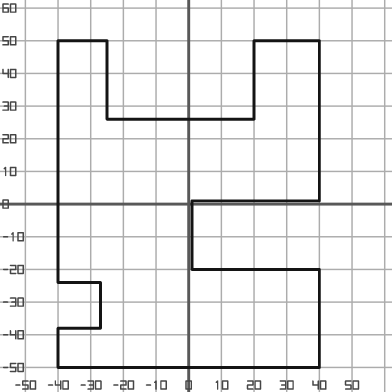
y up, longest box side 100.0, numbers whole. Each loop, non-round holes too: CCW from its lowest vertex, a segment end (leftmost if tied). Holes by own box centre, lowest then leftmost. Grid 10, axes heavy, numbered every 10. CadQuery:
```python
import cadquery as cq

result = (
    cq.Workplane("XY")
    .moveTo(-40.0, -50.0)
    .lineTo(40.0, -50.0)
    .lineTo(40.0, -20.0)
    .lineTo(1.0, -20.0)
    .lineTo(1.0, 1.0)
    .lineTo(40.0, 1.0)
    .lineTo(40.0, 50.0)
    .lineTo(20.0, 50.0)
    .lineTo(20.0, 26.0)
    .lineTo(-25.0, 26.0)
    .lineTo(-25.0, 50.0)
    .lineTo(-40.0, 50.0)
    .lineTo(-40.0, -24.0)
    .lineTo(-27.0, -24.0)
    .lineTo(-27.0, -38.0)
    .lineTo(-40.0, -38.0)
    .close()
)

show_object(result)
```